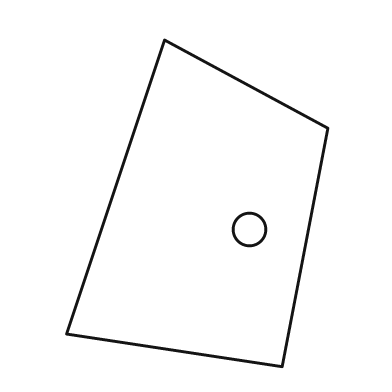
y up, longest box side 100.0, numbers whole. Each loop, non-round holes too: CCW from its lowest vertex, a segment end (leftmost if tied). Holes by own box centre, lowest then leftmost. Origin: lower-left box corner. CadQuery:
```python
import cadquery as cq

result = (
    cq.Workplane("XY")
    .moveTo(66.0, 0.0)
    .lineTo(80.0, 73.0)
    .lineTo(30.0, 100.0)
    .lineTo(0.0, 10.0)
    .close()
    .moveTo(56.0, 42.0)
    .circle(5.0)
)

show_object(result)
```